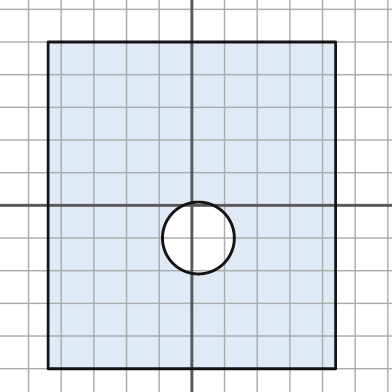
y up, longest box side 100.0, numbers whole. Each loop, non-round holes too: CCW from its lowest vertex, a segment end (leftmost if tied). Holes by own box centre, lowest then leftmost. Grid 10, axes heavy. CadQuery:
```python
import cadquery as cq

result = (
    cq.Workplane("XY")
    .moveTo(-44.0, -50.0)
    .lineTo(44.0, -50.0)
    .lineTo(44.0, 50.0)
    .lineTo(-44.0, 50.0)
    .close()
    .moveTo(2.0, -10.0)
    .circle(11.0)
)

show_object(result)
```